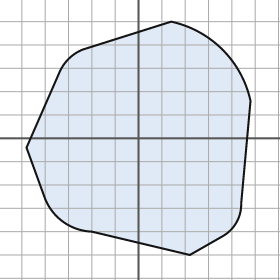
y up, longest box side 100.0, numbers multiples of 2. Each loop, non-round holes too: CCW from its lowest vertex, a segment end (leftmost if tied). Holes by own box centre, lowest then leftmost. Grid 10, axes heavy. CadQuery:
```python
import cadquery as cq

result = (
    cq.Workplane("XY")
    .moveTo(22.0, -50.0)
    .lineTo(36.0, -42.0)
    .threePointArc((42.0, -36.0), (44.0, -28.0))
    .lineTo(48.0, 16.0)
    .threePointArc((36.0, 38.0), (14.0, 50.0))
    .lineTo(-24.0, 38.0)
    .threePointArc((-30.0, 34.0), (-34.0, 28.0))
    .lineTo(-48.0, -4.0)
    .lineTo(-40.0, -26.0)
    .threePointArc((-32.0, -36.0), (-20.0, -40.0))
    .close()
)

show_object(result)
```